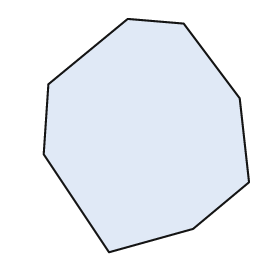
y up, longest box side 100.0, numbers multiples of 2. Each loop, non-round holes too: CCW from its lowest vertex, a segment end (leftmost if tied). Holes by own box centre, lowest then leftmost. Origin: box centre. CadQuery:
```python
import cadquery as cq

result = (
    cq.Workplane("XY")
    .moveTo(-16.0, -50.0)
    .lineTo(20.0, -40.0)
    .lineTo(44.0, -20.0)
    .lineTo(40.0, 16.0)
    .lineTo(16.0, 48.0)
    .lineTo(-8.0, 50.0)
    .lineTo(-42.0, 22.0)
    .lineTo(-44.0, -8.0)
    .close()
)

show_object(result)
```